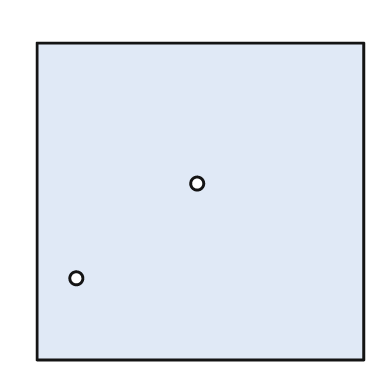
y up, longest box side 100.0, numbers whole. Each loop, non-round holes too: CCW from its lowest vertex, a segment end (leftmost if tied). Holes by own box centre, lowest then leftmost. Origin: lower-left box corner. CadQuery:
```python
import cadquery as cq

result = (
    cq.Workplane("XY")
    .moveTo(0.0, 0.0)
    .lineTo(100.0, 0.0)
    .lineTo(100.0, 97.0)
    .lineTo(0.0, 97.0)
    .close()
    .moveTo(12.0, 25.0)
    .circle(2.0)
    .moveTo(49.0, 54.0)
    .circle(2.0)
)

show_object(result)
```